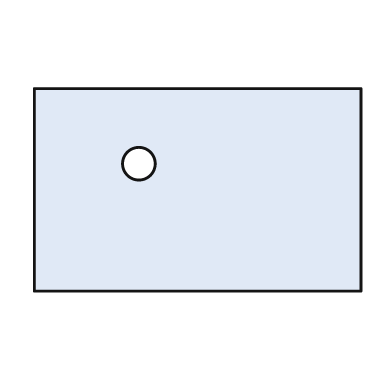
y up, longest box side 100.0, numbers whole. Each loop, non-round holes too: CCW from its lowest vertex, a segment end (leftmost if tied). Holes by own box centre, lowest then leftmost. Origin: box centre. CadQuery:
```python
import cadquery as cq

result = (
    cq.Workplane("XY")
    .moveTo(-50.0, -31.0)
    .lineTo(50.0, -31.0)
    .lineTo(50.0, 31.0)
    .lineTo(-50.0, 31.0)
    .close()
    .moveTo(-18.0, 8.0)
    .circle(5.0)
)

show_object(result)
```